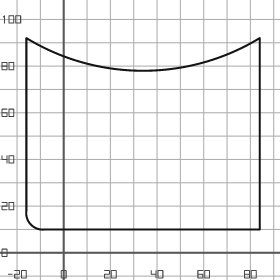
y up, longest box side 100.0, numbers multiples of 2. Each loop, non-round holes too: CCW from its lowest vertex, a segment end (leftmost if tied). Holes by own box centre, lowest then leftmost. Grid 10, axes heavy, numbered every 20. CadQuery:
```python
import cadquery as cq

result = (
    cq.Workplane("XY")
    .moveTo(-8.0, 10.0)
    .lineTo(84.0, 10.0)
    .lineTo(84.0, 92.0)
    .threePointArc((34.0, 78.0), (-16.0, 92.0))
    .lineTo(-16.0, 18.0)
    .threePointArc((-14.0, 12.0), (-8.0, 10.0))
    .close()
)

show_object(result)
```